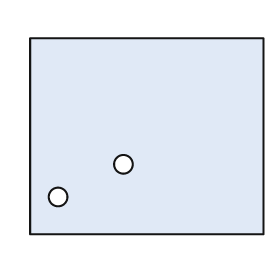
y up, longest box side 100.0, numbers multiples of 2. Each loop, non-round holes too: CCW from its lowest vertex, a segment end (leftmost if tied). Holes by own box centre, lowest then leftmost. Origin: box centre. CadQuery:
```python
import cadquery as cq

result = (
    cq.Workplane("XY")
    .moveTo(-50.0, -42.0)
    .lineTo(50.0, -42.0)
    .lineTo(50.0, 42.0)
    .lineTo(-50.0, 42.0)
    .close()
    .moveTo(-38.0, -26.0)
    .circle(4.0)
    .moveTo(-10.0, -12.0)
    .circle(4.0)
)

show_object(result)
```